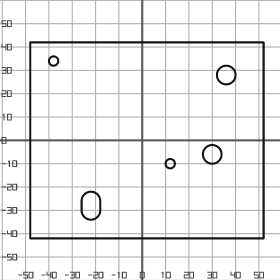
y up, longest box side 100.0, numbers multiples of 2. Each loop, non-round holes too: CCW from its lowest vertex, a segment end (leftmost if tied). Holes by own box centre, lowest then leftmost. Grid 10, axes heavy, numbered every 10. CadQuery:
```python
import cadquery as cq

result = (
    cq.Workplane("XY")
    .moveTo(-48.0, -42.0)
    .lineTo(52.0, -42.0)
    .lineTo(52.0, 42.0)
    .lineTo(-48.0, 42.0)
    .close()
    .moveTo(-26.0, -30.0)
    .threePointArc((-22.0, -34.0), (-18.0, -30.0))
    .lineTo(-18.0, -26.0)
    .threePointArc((-22.0, -22.0), (-26.0, -26.0))
    .close()
    .moveTo(12.0, -10.0)
    .circle(2.0)
    .moveTo(30.0, -6.0)
    .circle(4.0)
    .moveTo(36.0, 28.0)
    .circle(4.0)
    .moveTo(-38.0, 34.0)
    .circle(2.0)
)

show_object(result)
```